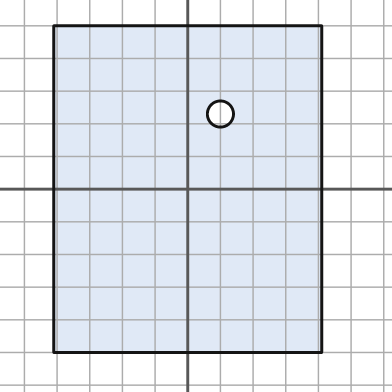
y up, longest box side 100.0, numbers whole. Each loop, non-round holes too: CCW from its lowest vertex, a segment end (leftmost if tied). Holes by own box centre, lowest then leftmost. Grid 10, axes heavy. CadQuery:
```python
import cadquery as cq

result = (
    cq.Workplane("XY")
    .moveTo(-41.0, -50.0)
    .lineTo(41.0, -50.0)
    .lineTo(41.0, 50.0)
    .lineTo(-41.0, 50.0)
    .close()
    .moveTo(10.0, 23.0)
    .circle(4.0)
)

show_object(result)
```